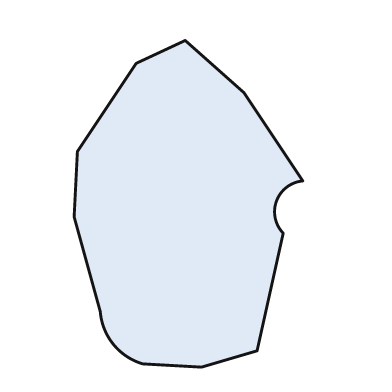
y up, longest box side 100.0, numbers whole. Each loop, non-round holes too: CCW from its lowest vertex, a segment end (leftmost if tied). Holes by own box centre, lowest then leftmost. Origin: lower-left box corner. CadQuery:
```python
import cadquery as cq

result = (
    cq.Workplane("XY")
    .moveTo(39.0, 0.0)
    .lineTo(56.0, 5.0)
    .lineTo(64.0, 41.0)
    .threePointArc((62.0, 51.0), (70.0, 57.0))
    .lineTo(52.0, 84.0)
    .lineTo(34.0, 100.0)
    .lineTo(19.0, 93.0)
    .lineTo(1.0, 66.0)
    .lineTo(0.0, 46.0)
    .lineTo(8.0, 17.0)
    .threePointArc((12.0, 7.0), (21.0, 1.0))
    .close()
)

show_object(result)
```